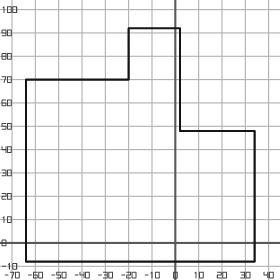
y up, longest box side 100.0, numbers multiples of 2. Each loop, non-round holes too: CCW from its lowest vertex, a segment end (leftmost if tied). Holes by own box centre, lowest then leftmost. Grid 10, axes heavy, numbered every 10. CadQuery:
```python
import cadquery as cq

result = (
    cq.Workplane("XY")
    .moveTo(-64.0, -8.0)
    .lineTo(34.0, -8.0)
    .lineTo(34.0, 48.0)
    .lineTo(2.0, 48.0)
    .lineTo(2.0, 92.0)
    .lineTo(-20.0, 92.0)
    .lineTo(-20.0, 70.0)
    .lineTo(-64.0, 70.0)
    .close()
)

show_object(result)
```